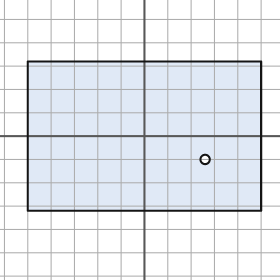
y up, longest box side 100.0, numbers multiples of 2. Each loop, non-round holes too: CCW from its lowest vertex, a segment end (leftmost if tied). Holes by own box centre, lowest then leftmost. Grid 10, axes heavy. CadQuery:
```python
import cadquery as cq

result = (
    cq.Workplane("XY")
    .moveTo(-50.0, -32.0)
    .lineTo(50.0, -32.0)
    .lineTo(50.0, 32.0)
    .lineTo(-50.0, 32.0)
    .close()
    .moveTo(26.0, -10.0)
    .circle(2.0)
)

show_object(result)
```